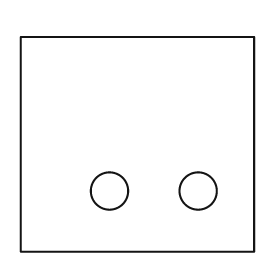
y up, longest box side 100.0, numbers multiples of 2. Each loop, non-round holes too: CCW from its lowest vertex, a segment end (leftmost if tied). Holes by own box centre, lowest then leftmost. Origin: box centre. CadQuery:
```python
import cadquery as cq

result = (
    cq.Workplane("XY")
    .moveTo(-50.0, -46.0)
    .lineTo(50.0, -46.0)
    .lineTo(50.0, 46.0)
    .lineTo(-50.0, 46.0)
    .close()
    .moveTo(-12.0, -20.0)
    .circle(8.0)
    .moveTo(26.0, -20.0)
    .circle(8.0)
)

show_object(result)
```